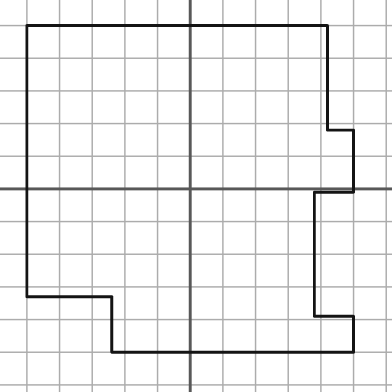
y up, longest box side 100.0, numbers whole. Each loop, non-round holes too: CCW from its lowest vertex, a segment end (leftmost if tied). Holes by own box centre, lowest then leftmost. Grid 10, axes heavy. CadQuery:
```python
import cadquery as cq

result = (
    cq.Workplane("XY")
    .moveTo(-24.0, -50.0)
    .lineTo(50.0, -50.0)
    .lineTo(50.0, -39.0)
    .lineTo(38.0, -39.0)
    .lineTo(38.0, -1.0)
    .lineTo(50.0, -1.0)
    .lineTo(50.0, 18.0)
    .lineTo(42.0, 18.0)
    .lineTo(42.0, 50.0)
    .lineTo(-50.0, 50.0)
    .lineTo(-50.0, -33.0)
    .lineTo(-24.0, -33.0)
    .close()
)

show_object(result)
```